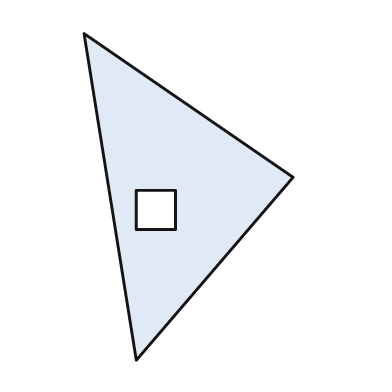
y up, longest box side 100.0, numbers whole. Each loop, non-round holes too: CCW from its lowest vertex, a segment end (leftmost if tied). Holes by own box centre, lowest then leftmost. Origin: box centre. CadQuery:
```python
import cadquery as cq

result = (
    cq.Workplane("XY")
    .moveTo(-16.0, -50.0)
    .lineTo(32.0, 6.0)
    .lineTo(-32.0, 50.0)
    .close()
    .moveTo(-16.0, -10.0)
    .lineTo(-4.0, -10.0)
    .lineTo(-4.0, 2.0)
    .lineTo(-16.0, 2.0)
    .close()
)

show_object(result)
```